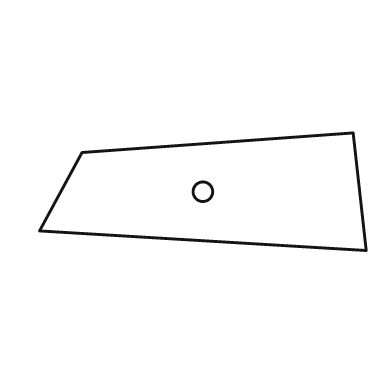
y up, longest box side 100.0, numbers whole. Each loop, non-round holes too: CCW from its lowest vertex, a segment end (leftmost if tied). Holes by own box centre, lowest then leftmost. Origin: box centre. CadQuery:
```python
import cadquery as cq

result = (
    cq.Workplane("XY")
    .moveTo(50.0, -18.0)
    .lineTo(46.0, 18.0)
    .lineTo(-37.0, 12.0)
    .lineTo(-50.0, -12.0)
    .close()
    .moveTo(0.0, 0.0)
    .circle(3.0)
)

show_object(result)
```